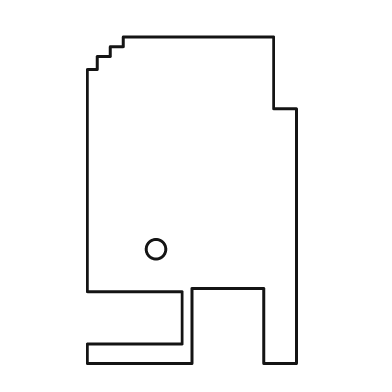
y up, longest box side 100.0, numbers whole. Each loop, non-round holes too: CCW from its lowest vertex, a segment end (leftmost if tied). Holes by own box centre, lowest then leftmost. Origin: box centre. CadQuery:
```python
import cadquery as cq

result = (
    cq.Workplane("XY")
    .moveTo(-32.0, -50.0)
    .lineTo(0.0, -50.0)
    .lineTo(0.0, -27.0)
    .lineTo(22.0, -27.0)
    .lineTo(22.0, -50.0)
    .lineTo(32.0, -50.0)
    .lineTo(32.0, 28.0)
    .lineTo(25.0, 28.0)
    .lineTo(25.0, 50.0)
    .lineTo(-21.0, 50.0)
    .lineTo(-21.0, 47.0)
    .lineTo(-25.0, 47.0)
    .lineTo(-25.0, 44.0)
    .lineTo(-29.0, 44.0)
    .lineTo(-29.0, 40.0)
    .lineTo(-32.0, 40.0)
    .lineTo(-32.0, -28.0)
    .lineTo(-3.0, -28.0)
    .lineTo(-3.0, -44.0)
    .lineTo(-32.0, -44.0)
    .close()
    .moveTo(-11.0, -15.0)
    .circle(3.0)
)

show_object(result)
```